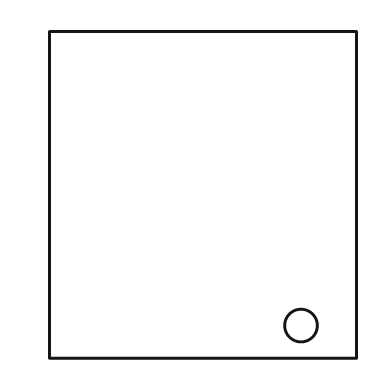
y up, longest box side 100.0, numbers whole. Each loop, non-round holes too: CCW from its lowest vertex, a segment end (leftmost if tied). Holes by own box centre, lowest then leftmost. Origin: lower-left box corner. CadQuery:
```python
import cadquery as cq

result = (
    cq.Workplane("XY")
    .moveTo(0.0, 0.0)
    .lineTo(94.0, 0.0)
    .lineTo(94.0, 100.0)
    .lineTo(0.0, 100.0)
    .close()
    .moveTo(77.0, 10.0)
    .circle(5.0)
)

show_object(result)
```